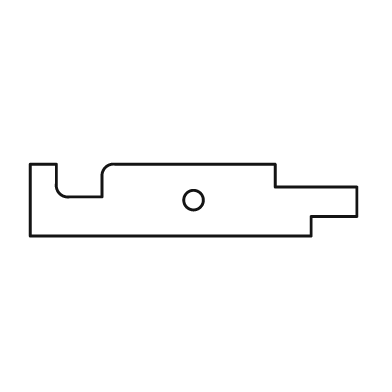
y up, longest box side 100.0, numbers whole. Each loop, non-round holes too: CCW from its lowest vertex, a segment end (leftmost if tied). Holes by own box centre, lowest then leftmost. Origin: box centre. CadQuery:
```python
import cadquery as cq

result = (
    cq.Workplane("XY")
    .moveTo(-50.0, -11.0)
    .lineTo(36.0, -11.0)
    .lineTo(36.0, -5.0)
    .lineTo(50.0, -5.0)
    .lineTo(50.0, 4.0)
    .lineTo(25.0, 4.0)
    .lineTo(25.0, 11.0)
    .lineTo(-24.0, 11.0)
    .threePointArc((-27.0, 10.0), (-28.0, 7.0))
    .lineTo(-28.0, 1.0)
    .lineTo(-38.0, 1.0)
    .threePointArc((-41.0, 2.0), (-42.0, 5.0))
    .lineTo(-42.0, 11.0)
    .lineTo(-50.0, 11.0)
    .close()
    .moveTo(0.0, 0.0)
    .circle(3.0)
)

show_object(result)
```